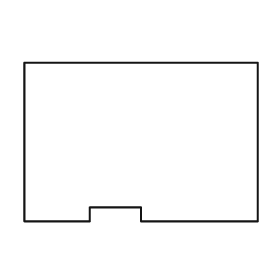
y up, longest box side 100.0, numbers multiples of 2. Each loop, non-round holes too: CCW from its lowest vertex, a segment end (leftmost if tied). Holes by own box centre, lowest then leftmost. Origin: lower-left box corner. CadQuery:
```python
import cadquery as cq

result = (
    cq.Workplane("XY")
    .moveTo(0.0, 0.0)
    .lineTo(28.0, 0.0)
    .lineTo(28.0, 6.0)
    .lineTo(50.0, 6.0)
    .lineTo(50.0, 0.0)
    .lineTo(100.0, 0.0)
    .lineTo(100.0, 68.0)
    .lineTo(0.0, 68.0)
    .close()
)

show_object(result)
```